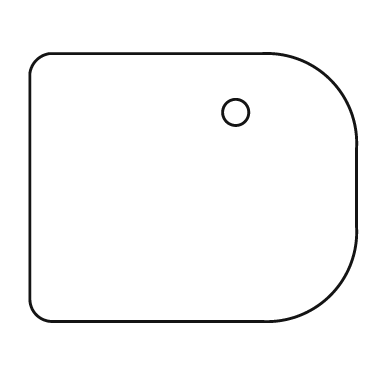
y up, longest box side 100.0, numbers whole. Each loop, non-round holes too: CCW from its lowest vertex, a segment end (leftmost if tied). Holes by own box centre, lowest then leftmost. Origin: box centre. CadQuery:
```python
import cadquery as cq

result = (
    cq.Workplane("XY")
    .moveTo(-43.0, -41.0)
    .lineTo(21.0, -41.0)
    .threePointArc((42.0, -33.0), (50.0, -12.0))
    .lineTo(50.0, 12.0)
    .threePointArc((42.0, 33.0), (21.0, 41.0))
    .lineTo(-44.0, 41.0)
    .threePointArc((-48.0, 39.0), (-50.0, 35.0))
    .lineTo(-50.0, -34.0)
    .threePointArc((-48.0, -39.0), (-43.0, -41.0))
    .close()
    .moveTo(13.0, 23.0)
    .circle(4.0)
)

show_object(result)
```